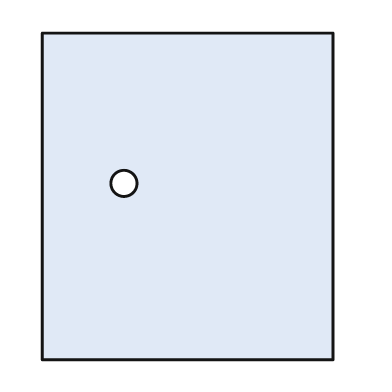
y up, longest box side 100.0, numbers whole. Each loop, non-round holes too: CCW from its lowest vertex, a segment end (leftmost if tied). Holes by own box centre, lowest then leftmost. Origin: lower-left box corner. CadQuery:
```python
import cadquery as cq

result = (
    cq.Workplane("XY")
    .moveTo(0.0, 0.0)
    .lineTo(89.0, 0.0)
    .lineTo(89.0, 100.0)
    .lineTo(0.0, 100.0)
    .close()
    .moveTo(25.0, 54.0)
    .circle(4.0)
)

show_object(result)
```